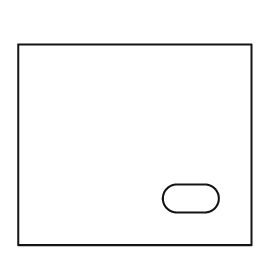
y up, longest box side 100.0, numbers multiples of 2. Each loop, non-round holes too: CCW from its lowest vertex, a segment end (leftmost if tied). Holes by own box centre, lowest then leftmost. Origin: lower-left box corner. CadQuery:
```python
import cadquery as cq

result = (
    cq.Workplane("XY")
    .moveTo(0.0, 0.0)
    .lineTo(100.0, 0.0)
    .lineTo(100.0, 86.0)
    .lineTo(0.0, 86.0)
    .close()
    .moveTo(68.0, 14.0)
    .lineTo(80.0, 14.0)
    .threePointArc((86.0, 20.0), (80.0, 26.0))
    .lineTo(68.0, 26.0)
    .threePointArc((62.0, 20.0), (68.0, 14.0))
    .close()
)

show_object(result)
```